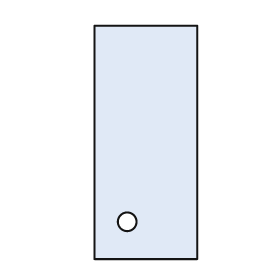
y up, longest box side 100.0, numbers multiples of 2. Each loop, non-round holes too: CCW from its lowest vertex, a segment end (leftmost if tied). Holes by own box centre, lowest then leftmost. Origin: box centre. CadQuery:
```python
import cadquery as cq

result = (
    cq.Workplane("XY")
    .moveTo(-22.0, -50.0)
    .lineTo(22.0, -50.0)
    .lineTo(22.0, 50.0)
    .lineTo(-22.0, 50.0)
    .close()
    .moveTo(-8.0, -34.0)
    .circle(4.0)
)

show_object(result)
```